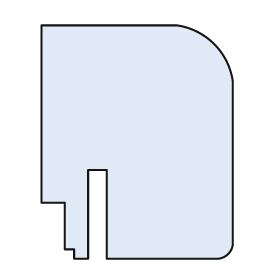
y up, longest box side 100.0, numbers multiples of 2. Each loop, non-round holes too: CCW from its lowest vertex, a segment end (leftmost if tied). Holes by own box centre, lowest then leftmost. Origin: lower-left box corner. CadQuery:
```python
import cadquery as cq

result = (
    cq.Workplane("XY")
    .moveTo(14.0, 0.0)
    .lineTo(20.0, 0.0)
    .lineTo(20.0, 38.0)
    .lineTo(28.0, 38.0)
    .lineTo(28.0, 0.0)
    .lineTo(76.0, 0.0)
    .threePointArc((80.0, 2.0), (82.0, 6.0))
    .lineTo(82.0, 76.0)
    .threePointArc((74.0, 92.0), (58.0, 100.0))
    .lineTo(0.0, 100.0)
    .lineTo(0.0, 24.0)
    .lineTo(10.0, 24.0)
    .lineTo(10.0, 4.0)
    .lineTo(14.0, 4.0)
    .close()
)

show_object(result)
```